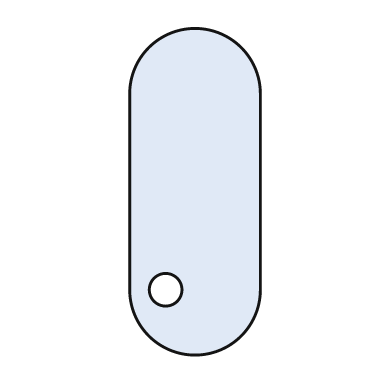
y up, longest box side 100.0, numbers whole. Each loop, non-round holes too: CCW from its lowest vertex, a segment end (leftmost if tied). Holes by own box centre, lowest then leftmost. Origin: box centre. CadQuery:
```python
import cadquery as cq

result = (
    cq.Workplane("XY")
    .moveTo(-20.0, -30.0)
    .threePointArc((0.0, -50.0), (20.0, -30.0))
    .lineTo(20.0, 30.0)
    .threePointArc((0.0, 50.0), (-20.0, 30.0))
    .close()
    .moveTo(-9.0, -30.0)
    .circle(5.0)
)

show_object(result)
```